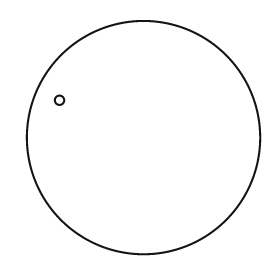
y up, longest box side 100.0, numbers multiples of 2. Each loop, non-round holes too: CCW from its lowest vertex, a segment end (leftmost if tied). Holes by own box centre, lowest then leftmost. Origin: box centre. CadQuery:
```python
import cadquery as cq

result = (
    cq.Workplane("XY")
    .moveTo(0.0, 0.0)
    .circle(50.0)
    .moveTo(-36.0, 16.0)
    .circle(2.0)
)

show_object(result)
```